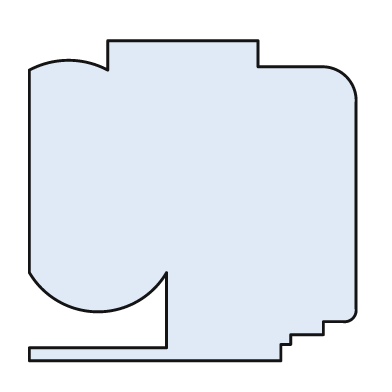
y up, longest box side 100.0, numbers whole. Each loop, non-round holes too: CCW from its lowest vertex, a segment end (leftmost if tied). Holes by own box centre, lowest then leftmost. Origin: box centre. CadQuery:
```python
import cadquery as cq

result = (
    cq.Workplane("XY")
    .moveTo(-50.0, -49.0)
    .lineTo(27.0, -49.0)
    .lineTo(27.0, -44.0)
    .lineTo(30.0, -44.0)
    .lineTo(30.0, -41.0)
    .lineTo(40.0, -41.0)
    .lineTo(40.0, -37.0)
    .lineTo(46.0, -37.0)
    .threePointArc((49.0, -36.0), (50.0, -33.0))
    .lineTo(50.0, 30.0)
    .threePointArc((47.0, 38.0), (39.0, 41.0))
    .lineTo(20.0, 41.0)
    .lineTo(20.0, 49.0)
    .lineTo(-26.0, 49.0)
    .lineTo(-26.0, 40.0)
    .threePointArc((-38.0, 43.0), (-50.0, 40.0))
    .lineTo(-50.0, -22.0)
    .threePointArc((-29.0, -34.0), (-8.0, -22.0))
    .lineTo(-8.0, -45.0)
    .lineTo(-50.0, -45.0)
    .close()
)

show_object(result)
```